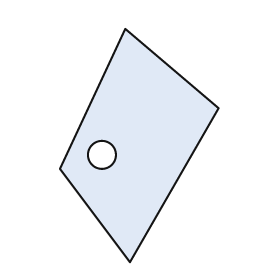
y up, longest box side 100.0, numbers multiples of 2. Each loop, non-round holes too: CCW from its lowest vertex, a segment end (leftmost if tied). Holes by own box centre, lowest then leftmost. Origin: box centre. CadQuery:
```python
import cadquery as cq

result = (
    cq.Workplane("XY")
    .moveTo(-4.0, -50.0)
    .lineTo(34.0, 16.0)
    .lineTo(-6.0, 50.0)
    .lineTo(-34.0, -10.0)
    .close()
    .moveTo(-16.0, -4.0)
    .circle(6.0)
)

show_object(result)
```